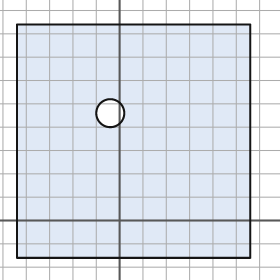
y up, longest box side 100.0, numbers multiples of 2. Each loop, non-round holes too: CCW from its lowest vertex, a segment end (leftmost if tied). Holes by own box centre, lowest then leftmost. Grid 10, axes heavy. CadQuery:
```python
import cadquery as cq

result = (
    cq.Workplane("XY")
    .moveTo(-44.0, -16.0)
    .lineTo(56.0, -16.0)
    .lineTo(56.0, 84.0)
    .lineTo(-44.0, 84.0)
    .close()
    .moveTo(-4.0, 46.0)
    .circle(6.0)
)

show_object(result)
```